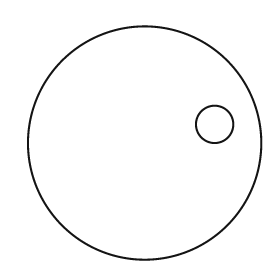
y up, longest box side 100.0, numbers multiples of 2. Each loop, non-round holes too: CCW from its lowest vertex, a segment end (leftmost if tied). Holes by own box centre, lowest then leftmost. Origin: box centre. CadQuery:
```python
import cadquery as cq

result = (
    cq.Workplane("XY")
    .moveTo(0.0, 0.0)
    .circle(50.0)
    .moveTo(30.0, 8.0)
    .circle(8.0)
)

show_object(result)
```